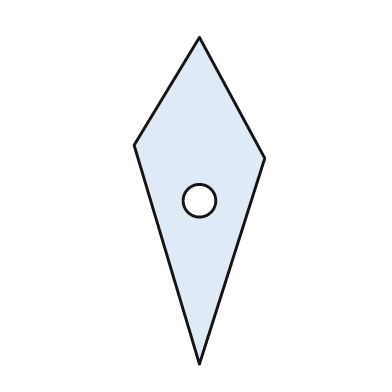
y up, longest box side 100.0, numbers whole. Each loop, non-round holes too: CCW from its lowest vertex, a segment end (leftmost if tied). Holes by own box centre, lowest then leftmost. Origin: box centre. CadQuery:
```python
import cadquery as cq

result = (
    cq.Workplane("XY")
    .moveTo(0.0, -50.0)
    .lineTo(20.0, 13.0)
    .lineTo(0.0, 50.0)
    .lineTo(-20.0, 17.0)
    .close()
    .moveTo(0.0, 0.0)
    .circle(5.0)
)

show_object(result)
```